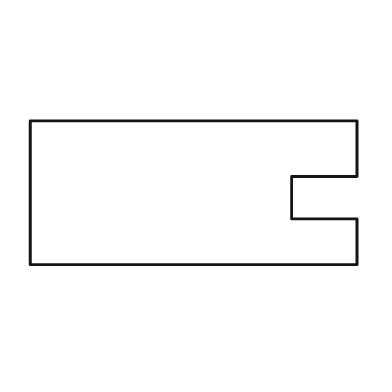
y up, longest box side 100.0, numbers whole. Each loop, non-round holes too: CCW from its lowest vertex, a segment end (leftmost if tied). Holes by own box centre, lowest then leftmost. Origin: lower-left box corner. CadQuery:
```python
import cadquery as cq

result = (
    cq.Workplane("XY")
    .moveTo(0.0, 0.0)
    .lineTo(100.0, 0.0)
    .lineTo(100.0, 14.0)
    .lineTo(80.0, 14.0)
    .lineTo(80.0, 27.0)
    .lineTo(100.0, 27.0)
    .lineTo(100.0, 44.0)
    .lineTo(0.0, 44.0)
    .close()
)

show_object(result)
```